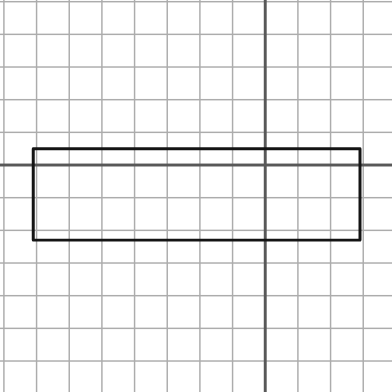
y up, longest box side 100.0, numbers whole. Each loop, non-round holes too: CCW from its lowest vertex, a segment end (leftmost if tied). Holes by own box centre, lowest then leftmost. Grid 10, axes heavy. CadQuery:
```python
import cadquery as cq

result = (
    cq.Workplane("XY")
    .moveTo(-71.0, -23.0)
    .lineTo(29.0, -23.0)
    .lineTo(29.0, 5.0)
    .lineTo(-71.0, 5.0)
    .close()
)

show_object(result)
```